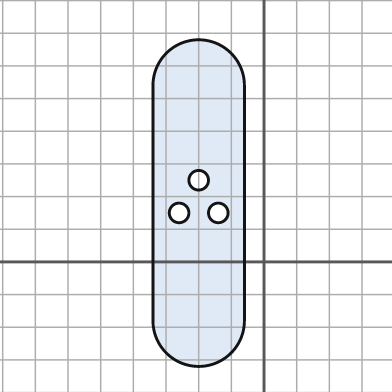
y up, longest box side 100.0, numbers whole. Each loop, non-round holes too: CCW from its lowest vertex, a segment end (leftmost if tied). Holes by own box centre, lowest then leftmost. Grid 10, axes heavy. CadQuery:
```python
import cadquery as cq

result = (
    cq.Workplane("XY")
    .moveTo(-34.0, -18.0)
    .threePointArc((-20.0, -32.0), (-6.0, -18.0))
    .lineTo(-6.0, 54.0)
    .threePointArc((-20.0, 68.0), (-34.0, 54.0))
    .close()
    .moveTo(-26.0, 15.0)
    .circle(3.0)
    .moveTo(-14.0, 15.0)
    .circle(3.0)
    .moveTo(-20.0, 25.0)
    .circle(3.0)
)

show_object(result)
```